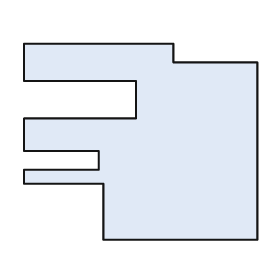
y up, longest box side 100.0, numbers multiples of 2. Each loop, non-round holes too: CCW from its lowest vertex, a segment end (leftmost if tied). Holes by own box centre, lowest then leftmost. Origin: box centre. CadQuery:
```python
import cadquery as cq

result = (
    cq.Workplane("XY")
    .moveTo(-16.0, -42.0)
    .lineTo(50.0, -42.0)
    .lineTo(50.0, 34.0)
    .lineTo(14.0, 34.0)
    .lineTo(14.0, 42.0)
    .lineTo(-50.0, 42.0)
    .lineTo(-50.0, 26.0)
    .lineTo(-2.0, 26.0)
    .lineTo(-2.0, 10.0)
    .lineTo(-50.0, 10.0)
    .lineTo(-50.0, -4.0)
    .lineTo(-18.0, -4.0)
    .lineTo(-18.0, -12.0)
    .lineTo(-50.0, -12.0)
    .lineTo(-50.0, -18.0)
    .lineTo(-16.0, -18.0)
    .close()
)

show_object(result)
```